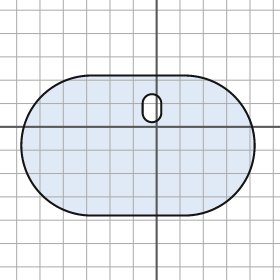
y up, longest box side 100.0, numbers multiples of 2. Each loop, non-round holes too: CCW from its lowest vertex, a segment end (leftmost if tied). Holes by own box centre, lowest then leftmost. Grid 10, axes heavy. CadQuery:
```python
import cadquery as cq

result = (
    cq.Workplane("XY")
    .moveTo(-28.0, -38.0)
    .lineTo(12.0, -38.0)
    .threePointArc((42.0, -8.0), (12.0, 22.0))
    .lineTo(-28.0, 22.0)
    .threePointArc((-58.0, -8.0), (-28.0, -38.0))
    .close()
    .moveTo(-6.0, 6.0)
    .threePointArc((-2.0, 2.0), (2.0, 6.0))
    .lineTo(2.0, 10.0)
    .threePointArc((-2.0, 14.0), (-6.0, 10.0))
    .close()
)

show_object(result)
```